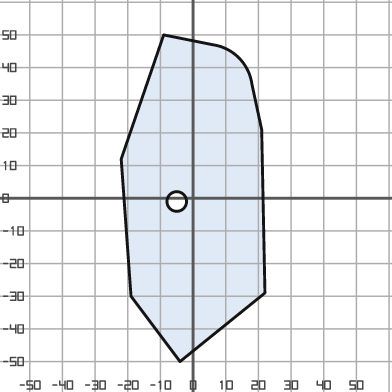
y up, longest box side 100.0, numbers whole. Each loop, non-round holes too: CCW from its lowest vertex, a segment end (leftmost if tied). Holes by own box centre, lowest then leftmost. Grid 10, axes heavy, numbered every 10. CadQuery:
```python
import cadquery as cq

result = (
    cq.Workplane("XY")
    .moveTo(-4.0, -50.0)
    .lineTo(22.0, -29.0)
    .lineTo(21.0, 21.0)
    .lineTo(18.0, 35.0)
    .threePointArc((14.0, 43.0), (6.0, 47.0))
    .lineTo(-9.0, 50.0)
    .lineTo(-22.0, 12.0)
    .lineTo(-19.0, -30.0)
    .close()
    .moveTo(-5.0, -1.0)
    .circle(3.0)
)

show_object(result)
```